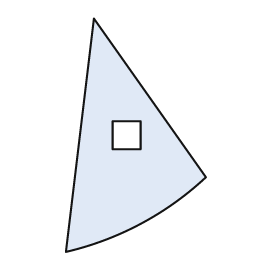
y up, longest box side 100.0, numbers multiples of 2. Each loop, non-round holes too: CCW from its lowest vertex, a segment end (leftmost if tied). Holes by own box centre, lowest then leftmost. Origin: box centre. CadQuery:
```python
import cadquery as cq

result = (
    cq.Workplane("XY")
    .moveTo(-30.0, -50.0)
    .threePointArc((2.0, -38.0), (30.0, -18.0))
    .lineTo(-18.0, 50.0)
    .close()
    .moveTo(-10.0, -6.0)
    .lineTo(2.0, -6.0)
    .lineTo(2.0, 6.0)
    .lineTo(-10.0, 6.0)
    .close()
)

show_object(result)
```